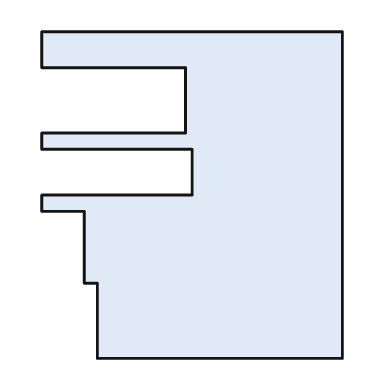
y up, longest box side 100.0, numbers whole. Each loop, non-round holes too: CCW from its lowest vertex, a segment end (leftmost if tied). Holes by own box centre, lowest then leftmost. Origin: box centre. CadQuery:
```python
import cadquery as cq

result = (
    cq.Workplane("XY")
    .moveTo(-29.0, -50.0)
    .lineTo(46.0, -50.0)
    .lineTo(46.0, 50.0)
    .lineTo(-46.0, 50.0)
    .lineTo(-46.0, 39.0)
    .lineTo(-2.0, 39.0)
    .lineTo(-2.0, 19.0)
    .lineTo(-46.0, 19.0)
    .lineTo(-46.0, 14.0)
    .lineTo(0.0, 14.0)
    .lineTo(0.0, 0.0)
    .lineTo(-46.0, 0.0)
    .lineTo(-46.0, -5.0)
    .lineTo(-33.0, -5.0)
    .lineTo(-33.0, -27.0)
    .lineTo(-29.0, -27.0)
    .close()
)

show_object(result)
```